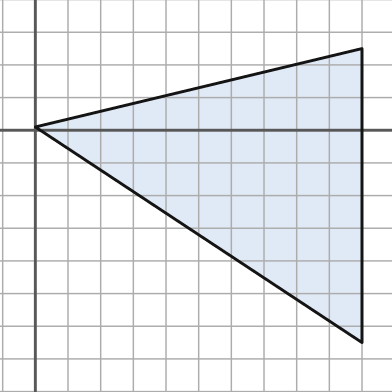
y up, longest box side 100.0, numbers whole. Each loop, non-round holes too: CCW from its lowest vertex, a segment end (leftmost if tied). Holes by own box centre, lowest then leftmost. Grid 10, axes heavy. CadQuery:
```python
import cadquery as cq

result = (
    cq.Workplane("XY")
    .moveTo(100.0, -65.0)
    .lineTo(100.0, 25.0)
    .lineTo(0.0, 1.0)
    .close()
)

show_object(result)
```